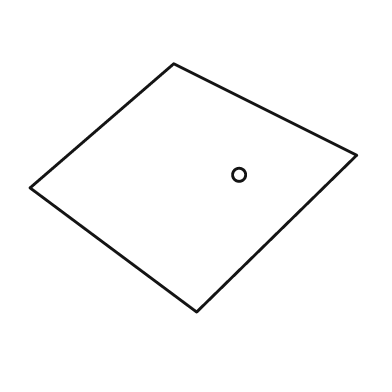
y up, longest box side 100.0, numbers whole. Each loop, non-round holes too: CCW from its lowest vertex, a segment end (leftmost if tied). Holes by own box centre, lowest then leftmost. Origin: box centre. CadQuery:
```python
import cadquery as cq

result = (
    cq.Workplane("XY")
    .moveTo(1.0, -38.0)
    .lineTo(50.0, 10.0)
    .lineTo(-6.0, 38.0)
    .lineTo(-50.0, 0.0)
    .close()
    .moveTo(14.0, 4.0)
    .circle(2.0)
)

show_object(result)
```